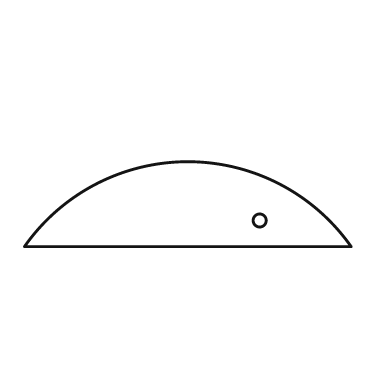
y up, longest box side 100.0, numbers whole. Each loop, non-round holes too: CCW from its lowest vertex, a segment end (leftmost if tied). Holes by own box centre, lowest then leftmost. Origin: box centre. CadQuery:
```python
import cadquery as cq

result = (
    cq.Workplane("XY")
    .moveTo(-50.0, -13.0)
    .lineTo(50.0, -13.0)
    .threePointArc((0.0, 13.0), (-50.0, -13.0))
    .close()
    .moveTo(22.0, -5.0)
    .circle(2.0)
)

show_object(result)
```